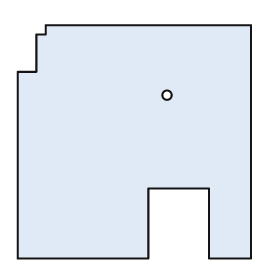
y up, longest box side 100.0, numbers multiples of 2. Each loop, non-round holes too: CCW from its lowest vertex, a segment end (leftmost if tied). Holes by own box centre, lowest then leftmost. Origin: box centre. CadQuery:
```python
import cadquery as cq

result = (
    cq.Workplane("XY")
    .moveTo(-50.0, -50.0)
    .lineTo(6.0, -50.0)
    .lineTo(6.0, -20.0)
    .lineTo(32.0, -20.0)
    .lineTo(32.0, -50.0)
    .lineTo(50.0, -50.0)
    .lineTo(50.0, 50.0)
    .lineTo(-38.0, 50.0)
    .lineTo(-38.0, 46.0)
    .lineTo(-42.0, 46.0)
    .lineTo(-42.0, 30.0)
    .lineTo(-50.0, 30.0)
    .close()
    .moveTo(14.0, 20.0)
    .circle(2.0)
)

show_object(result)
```